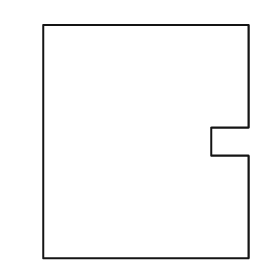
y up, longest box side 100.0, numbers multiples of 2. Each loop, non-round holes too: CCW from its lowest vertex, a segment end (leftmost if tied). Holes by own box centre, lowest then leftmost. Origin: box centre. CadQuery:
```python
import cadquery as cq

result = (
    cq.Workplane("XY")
    .moveTo(-44.0, -50.0)
    .lineTo(44.0, -50.0)
    .lineTo(44.0, -6.0)
    .lineTo(28.0, -6.0)
    .lineTo(28.0, 6.0)
    .lineTo(44.0, 6.0)
    .lineTo(44.0, 50.0)
    .lineTo(-44.0, 50.0)
    .close()
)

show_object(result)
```